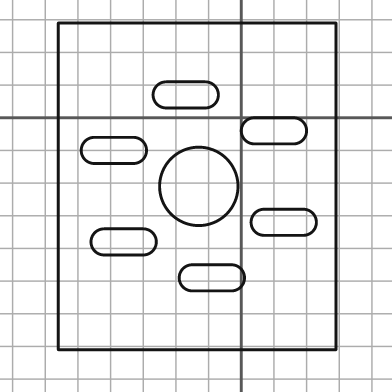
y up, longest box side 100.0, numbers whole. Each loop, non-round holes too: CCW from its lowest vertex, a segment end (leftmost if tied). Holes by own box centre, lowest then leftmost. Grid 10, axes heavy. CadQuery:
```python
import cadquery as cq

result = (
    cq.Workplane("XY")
    .moveTo(-56.0, -71.0)
    .lineTo(29.0, -71.0)
    .lineTo(29.0, 29.0)
    .lineTo(-56.0, 29.0)
    .close()
    .moveTo(-15.0, -53.0)
    .lineTo(-3.0, -53.0)
    .threePointArc((1.0, -49.0), (-3.0, -45.0))
    .lineTo(-15.0, -45.0)
    .threePointArc((-19.0, -49.0), (-15.0, -53.0))
    .close()
    .moveTo(-42.0, -42.0)
    .lineTo(-30.0, -42.0)
    .threePointArc((-26.0, -38.0), (-30.0, -34.0))
    .lineTo(-42.0, -34.0)
    .threePointArc((-46.0, -38.0), (-42.0, -42.0))
    .close()
    .moveTo(7.0, -36.0)
    .lineTo(19.0, -36.0)
    .threePointArc((23.0, -32.0), (19.0, -28.0))
    .lineTo(7.0, -28.0)
    .threePointArc((3.0, -32.0), (7.0, -36.0))
    .close()
    .moveTo(-13.0, -21.0)
    .circle(12.0)
    .moveTo(-45.0, -14.0)
    .lineTo(-33.0, -14.0)
    .threePointArc((-29.0, -10.0), (-33.0, -6.0))
    .lineTo(-45.0, -6.0)
    .threePointArc((-49.0, -10.0), (-45.0, -14.0))
    .close()
    .moveTo(4.0, -8.0)
    .lineTo(16.0, -8.0)
    .threePointArc((20.0, -4.0), (16.0, 0.0))
    .lineTo(4.0, 0.0)
    .threePointArc((0.0, -4.0), (4.0, -8.0))
    .close()
    .moveTo(-23.0, 3.0)
    .lineTo(-11.0, 3.0)
    .threePointArc((-7.0, 7.0), (-11.0, 11.0))
    .lineTo(-23.0, 11.0)
    .threePointArc((-27.0, 7.0), (-23.0, 3.0))
    .close()
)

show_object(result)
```